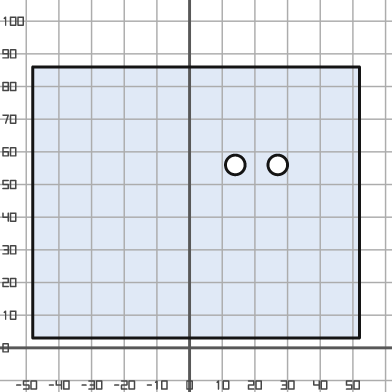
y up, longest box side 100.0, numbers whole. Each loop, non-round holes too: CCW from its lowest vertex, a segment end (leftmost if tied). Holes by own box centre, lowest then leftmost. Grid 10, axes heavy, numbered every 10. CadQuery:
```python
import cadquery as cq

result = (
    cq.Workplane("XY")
    .moveTo(-48.0, 3.0)
    .lineTo(52.0, 3.0)
    .lineTo(52.0, 86.0)
    .lineTo(-48.0, 86.0)
    .close()
    .moveTo(14.0, 56.0)
    .circle(3.0)
    .moveTo(27.0, 56.0)
    .circle(3.0)
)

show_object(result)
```